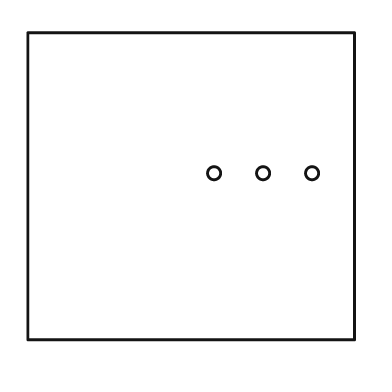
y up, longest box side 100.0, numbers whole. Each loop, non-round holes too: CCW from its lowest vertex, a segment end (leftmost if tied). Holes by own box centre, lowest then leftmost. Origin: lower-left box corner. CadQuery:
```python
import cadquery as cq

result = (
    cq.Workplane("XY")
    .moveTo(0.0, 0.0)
    .lineTo(100.0, 0.0)
    .lineTo(100.0, 94.0)
    .lineTo(0.0, 94.0)
    .close()
    .moveTo(57.0, 51.0)
    .circle(2.0)
    .moveTo(72.0, 51.0)
    .circle(2.0)
    .moveTo(87.0, 51.0)
    .circle(2.0)
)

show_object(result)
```